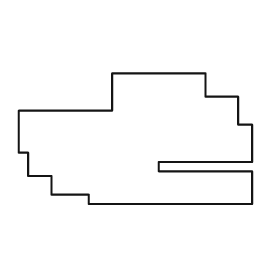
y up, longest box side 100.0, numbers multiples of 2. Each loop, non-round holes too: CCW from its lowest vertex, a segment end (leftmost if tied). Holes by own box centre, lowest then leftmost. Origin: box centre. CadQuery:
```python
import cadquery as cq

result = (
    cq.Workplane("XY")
    .moveTo(-20.0, -28.0)
    .lineTo(50.0, -28.0)
    .lineTo(50.0, -14.0)
    .lineTo(10.0, -14.0)
    .lineTo(10.0, -10.0)
    .lineTo(50.0, -10.0)
    .lineTo(50.0, 6.0)
    .lineTo(44.0, 6.0)
    .lineTo(44.0, 18.0)
    .lineTo(30.0, 18.0)
    .lineTo(30.0, 28.0)
    .lineTo(-10.0, 28.0)
    .lineTo(-10.0, 12.0)
    .lineTo(-50.0, 12.0)
    .lineTo(-50.0, -6.0)
    .lineTo(-46.0, -6.0)
    .lineTo(-46.0, -16.0)
    .lineTo(-36.0, -16.0)
    .lineTo(-36.0, -24.0)
    .lineTo(-20.0, -24.0)
    .close()
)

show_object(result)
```